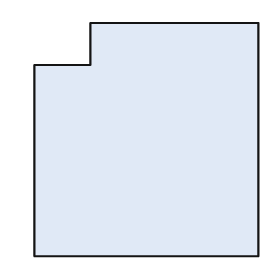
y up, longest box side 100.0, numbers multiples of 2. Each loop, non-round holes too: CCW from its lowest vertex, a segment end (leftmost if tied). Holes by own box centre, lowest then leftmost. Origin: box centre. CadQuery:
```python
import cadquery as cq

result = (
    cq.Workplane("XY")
    .moveTo(-48.0, -50.0)
    .lineTo(48.0, -50.0)
    .lineTo(48.0, 50.0)
    .lineTo(-24.0, 50.0)
    .lineTo(-24.0, 32.0)
    .lineTo(-48.0, 32.0)
    .close()
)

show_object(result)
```